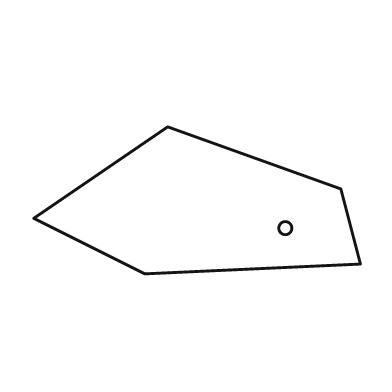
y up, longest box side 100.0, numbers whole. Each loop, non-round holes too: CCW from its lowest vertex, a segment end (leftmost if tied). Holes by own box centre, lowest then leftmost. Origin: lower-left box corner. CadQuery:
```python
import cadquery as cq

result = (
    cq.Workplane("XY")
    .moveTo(34.0, 0.0)
    .lineTo(100.0, 3.0)
    .lineTo(94.0, 26.0)
    .lineTo(41.0, 45.0)
    .lineTo(0.0, 17.0)
    .close()
    .moveTo(77.0, 14.0)
    .circle(2.0)
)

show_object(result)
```